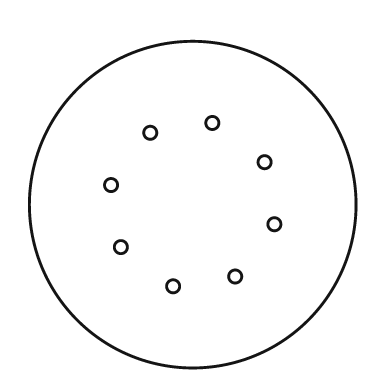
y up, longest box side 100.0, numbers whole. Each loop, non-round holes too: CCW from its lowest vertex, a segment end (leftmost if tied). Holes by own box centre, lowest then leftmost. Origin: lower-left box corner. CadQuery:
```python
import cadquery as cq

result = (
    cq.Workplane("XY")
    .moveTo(50.0, 50.0)
    .circle(50.0)
    .moveTo(44.0, 25.0)
    .circle(2.0)
    .moveTo(63.0, 28.0)
    .circle(2.0)
    .moveTo(28.0, 37.0)
    .circle(2.0)
    .moveTo(75.0, 44.0)
    .circle(2.0)
    .moveTo(25.0, 56.0)
    .circle(2.0)
    .moveTo(72.0, 63.0)
    .circle(2.0)
    .moveTo(37.0, 72.0)
    .circle(2.0)
    .moveTo(56.0, 75.0)
    .circle(2.0)
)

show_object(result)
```